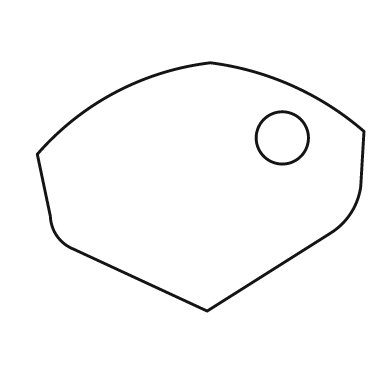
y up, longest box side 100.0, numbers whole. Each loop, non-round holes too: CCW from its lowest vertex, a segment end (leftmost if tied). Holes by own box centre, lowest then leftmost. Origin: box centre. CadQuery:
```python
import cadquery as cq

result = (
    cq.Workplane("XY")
    .moveTo(2.0, -38.0)
    .lineTo(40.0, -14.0)
    .threePointArc((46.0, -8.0), (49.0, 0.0))
    .lineTo(50.0, 17.0)
    .threePointArc((28.0, 31.0), (3.0, 38.0))
    .threePointArc((-26.0, 29.0), (-50.0, 10.0))
    .lineTo(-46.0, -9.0)
    .threePointArc((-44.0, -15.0), (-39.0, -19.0))
    .close()
    .moveTo(25.0, 15.0)
    .circle(8.0)
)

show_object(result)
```